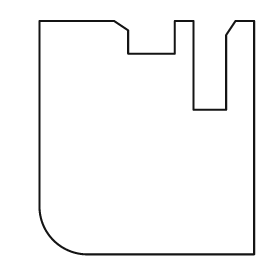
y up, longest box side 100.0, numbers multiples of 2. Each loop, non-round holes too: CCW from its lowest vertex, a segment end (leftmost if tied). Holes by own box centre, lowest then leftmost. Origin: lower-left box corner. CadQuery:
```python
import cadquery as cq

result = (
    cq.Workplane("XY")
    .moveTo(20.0, 0.0)
    .lineTo(92.0, 0.0)
    .lineTo(92.0, 100.0)
    .lineTo(84.0, 100.0)
    .lineTo(80.0, 94.0)
    .lineTo(80.0, 62.0)
    .lineTo(66.0, 62.0)
    .lineTo(66.0, 100.0)
    .lineTo(58.0, 100.0)
    .lineTo(58.0, 86.0)
    .lineTo(38.0, 86.0)
    .lineTo(38.0, 96.0)
    .lineTo(32.0, 100.0)
    .lineTo(0.0, 100.0)
    .lineTo(0.0, 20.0)
    .threePointArc((6.0, 6.0), (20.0, 0.0))
    .close()
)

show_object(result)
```